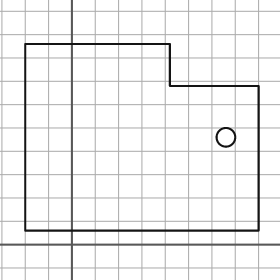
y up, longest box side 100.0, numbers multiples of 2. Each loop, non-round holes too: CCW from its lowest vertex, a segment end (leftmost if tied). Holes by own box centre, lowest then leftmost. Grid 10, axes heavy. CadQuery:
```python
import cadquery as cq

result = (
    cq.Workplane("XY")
    .moveTo(-20.0, 6.0)
    .lineTo(80.0, 6.0)
    .lineTo(80.0, 68.0)
    .lineTo(42.0, 68.0)
    .lineTo(42.0, 86.0)
    .lineTo(-20.0, 86.0)
    .close()
    .moveTo(66.0, 46.0)
    .circle(4.0)
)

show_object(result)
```